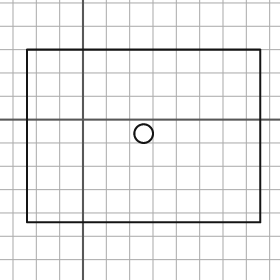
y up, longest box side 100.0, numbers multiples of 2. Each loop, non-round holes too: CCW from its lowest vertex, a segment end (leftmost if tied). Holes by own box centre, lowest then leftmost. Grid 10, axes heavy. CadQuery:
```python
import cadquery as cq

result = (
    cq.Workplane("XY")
    .moveTo(-24.0, -44.0)
    .lineTo(76.0, -44.0)
    .lineTo(76.0, 30.0)
    .lineTo(-24.0, 30.0)
    .close()
    .moveTo(26.0, -6.0)
    .circle(4.0)
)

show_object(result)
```